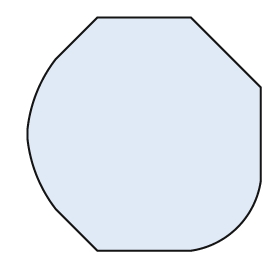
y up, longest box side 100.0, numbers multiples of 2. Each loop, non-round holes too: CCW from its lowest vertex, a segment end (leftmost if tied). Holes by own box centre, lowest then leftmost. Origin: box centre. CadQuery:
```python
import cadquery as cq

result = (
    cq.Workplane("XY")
    .moveTo(-20.0, -50.0)
    .lineTo(20.0, -50.0)
    .threePointArc((40.0, -40.0), (50.0, -20.0))
    .lineTo(50.0, 20.0)
    .lineTo(20.0, 50.0)
    .lineTo(-20.0, 50.0)
    .lineTo(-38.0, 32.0)
    .threePointArc((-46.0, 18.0), (-50.0, 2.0))
    .lineTo(-50.0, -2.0)
    .threePointArc((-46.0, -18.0), (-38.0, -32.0))
    .close()
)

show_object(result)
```